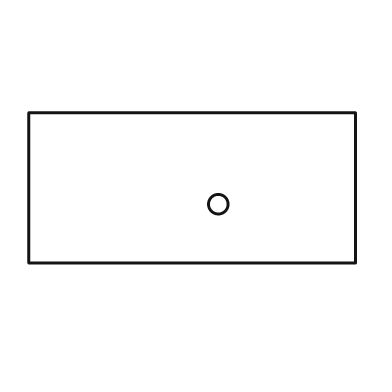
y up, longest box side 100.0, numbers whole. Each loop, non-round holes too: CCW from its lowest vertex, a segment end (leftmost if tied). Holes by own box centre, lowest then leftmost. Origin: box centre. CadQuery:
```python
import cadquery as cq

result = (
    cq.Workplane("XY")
    .moveTo(-50.0, -23.0)
    .lineTo(50.0, -23.0)
    .lineTo(50.0, 23.0)
    .lineTo(-50.0, 23.0)
    .close()
    .moveTo(8.0, -5.0)
    .circle(3.0)
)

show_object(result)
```